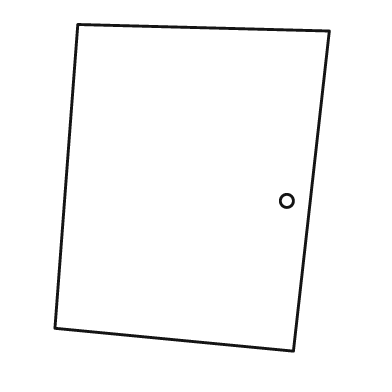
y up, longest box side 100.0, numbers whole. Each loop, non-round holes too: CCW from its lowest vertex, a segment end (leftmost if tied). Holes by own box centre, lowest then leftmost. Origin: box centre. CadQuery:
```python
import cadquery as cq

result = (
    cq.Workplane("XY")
    .moveTo(31.0, -50.0)
    .lineTo(42.0, 48.0)
    .lineTo(-35.0, 50.0)
    .lineTo(-42.0, -43.0)
    .close()
    .moveTo(29.0, -4.0)
    .circle(2.0)
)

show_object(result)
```